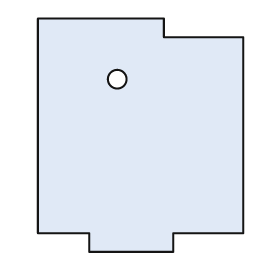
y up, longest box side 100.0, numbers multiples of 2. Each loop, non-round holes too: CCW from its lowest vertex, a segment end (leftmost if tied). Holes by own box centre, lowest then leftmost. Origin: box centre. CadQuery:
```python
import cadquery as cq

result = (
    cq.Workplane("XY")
    .moveTo(-22.0, -50.0)
    .lineTo(14.0, -50.0)
    .lineTo(14.0, -42.0)
    .lineTo(44.0, -42.0)
    .lineTo(44.0, 42.0)
    .lineTo(10.0, 42.0)
    .lineTo(10.0, 50.0)
    .lineTo(-44.0, 50.0)
    .lineTo(-44.0, -42.0)
    .lineTo(-22.0, -42.0)
    .close()
    .moveTo(-10.0, 24.0)
    .circle(4.0)
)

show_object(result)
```